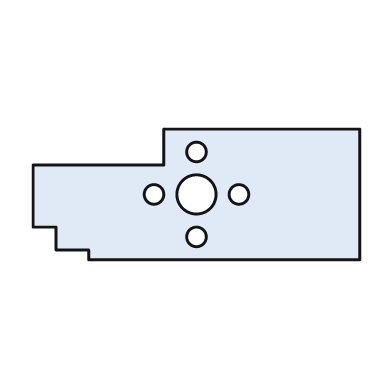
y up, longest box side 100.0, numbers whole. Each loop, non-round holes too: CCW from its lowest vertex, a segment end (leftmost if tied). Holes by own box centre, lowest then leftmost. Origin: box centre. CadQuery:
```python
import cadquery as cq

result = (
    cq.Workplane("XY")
    .moveTo(-33.0, -20.0)
    .lineTo(50.0, -20.0)
    .lineTo(50.0, 20.0)
    .lineTo(-10.0, 20.0)
    .lineTo(-10.0, 9.0)
    .lineTo(-50.0, 9.0)
    .lineTo(-50.0, -10.0)
    .lineTo(-43.0, -10.0)
    .lineTo(-43.0, -17.0)
    .lineTo(-33.0, -17.0)
    .close()
    .moveTo(0.0, -13.0)
    .circle(3.0)
    .moveTo(-13.0, 0.0)
    .circle(3.0)
    .moveTo(0.0, 0.0)
    .circle(6.0)
    .moveTo(13.0, 0.0)
    .circle(3.0)
    .moveTo(0.0, 13.0)
    .circle(3.0)
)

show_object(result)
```